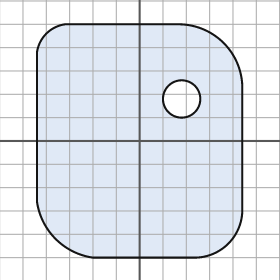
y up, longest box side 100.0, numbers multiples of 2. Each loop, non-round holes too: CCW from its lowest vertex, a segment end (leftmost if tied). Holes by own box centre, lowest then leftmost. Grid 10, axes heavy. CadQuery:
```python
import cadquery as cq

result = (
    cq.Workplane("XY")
    .moveTo(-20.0, -50.0)
    .lineTo(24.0, -50.0)
    .threePointArc((38.0, -44.0), (44.0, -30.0))
    .lineTo(44.0, 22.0)
    .threePointArc((36.0, 42.0), (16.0, 50.0))
    .lineTo(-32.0, 50.0)
    .threePointArc((-40.0, 46.0), (-44.0, 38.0))
    .lineTo(-44.0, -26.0)
    .threePointArc((-36.0, -42.0), (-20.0, -50.0))
    .close()
    .moveTo(18.0, 18.0)
    .circle(8.0)
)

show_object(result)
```